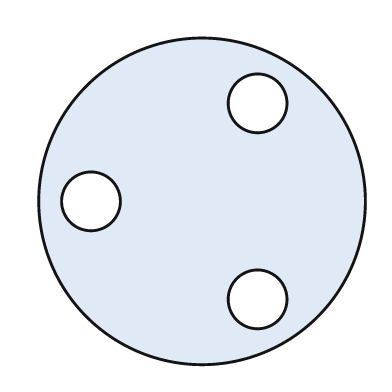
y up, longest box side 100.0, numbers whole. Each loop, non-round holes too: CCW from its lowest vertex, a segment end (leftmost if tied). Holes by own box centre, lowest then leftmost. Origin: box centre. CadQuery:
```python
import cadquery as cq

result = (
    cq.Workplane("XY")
    .moveTo(0.0, 0.0)
    .circle(50.0)
    .moveTo(17.0, -30.0)
    .circle(9.0)
    .moveTo(-34.0, 0.0)
    .circle(9.0)
    .moveTo(17.0, 30.0)
    .circle(9.0)
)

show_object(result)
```